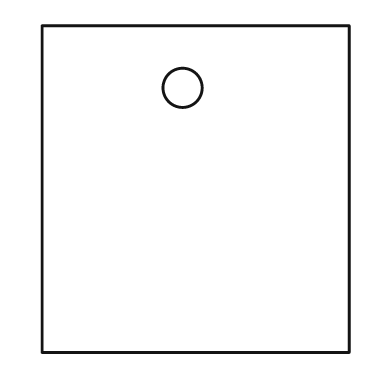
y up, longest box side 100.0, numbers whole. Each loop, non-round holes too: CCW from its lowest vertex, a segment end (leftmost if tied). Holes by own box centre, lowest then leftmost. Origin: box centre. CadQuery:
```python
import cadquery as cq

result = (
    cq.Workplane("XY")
    .moveTo(-47.0, -50.0)
    .lineTo(47.0, -50.0)
    .lineTo(47.0, 50.0)
    .lineTo(-47.0, 50.0)
    .close()
    .moveTo(-4.0, 31.0)
    .circle(6.0)
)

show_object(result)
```